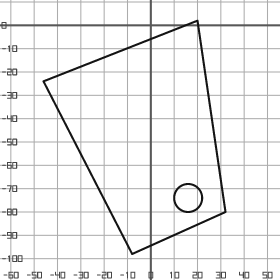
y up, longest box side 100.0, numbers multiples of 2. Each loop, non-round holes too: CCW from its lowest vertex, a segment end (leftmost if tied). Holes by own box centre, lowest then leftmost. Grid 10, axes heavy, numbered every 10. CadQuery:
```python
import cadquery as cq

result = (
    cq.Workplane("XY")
    .moveTo(-8.0, -98.0)
    .lineTo(32.0, -80.0)
    .lineTo(20.0, 2.0)
    .lineTo(-46.0, -24.0)
    .close()
    .moveTo(16.0, -74.0)
    .circle(6.0)
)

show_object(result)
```